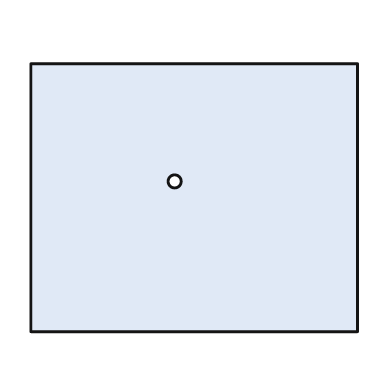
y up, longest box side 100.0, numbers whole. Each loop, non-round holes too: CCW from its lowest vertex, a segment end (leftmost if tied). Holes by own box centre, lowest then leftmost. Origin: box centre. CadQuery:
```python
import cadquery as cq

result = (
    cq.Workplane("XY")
    .moveTo(-50.0, -41.0)
    .lineTo(50.0, -41.0)
    .lineTo(50.0, 41.0)
    .lineTo(-50.0, 41.0)
    .close()
    .moveTo(-6.0, 5.0)
    .circle(2.0)
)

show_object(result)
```